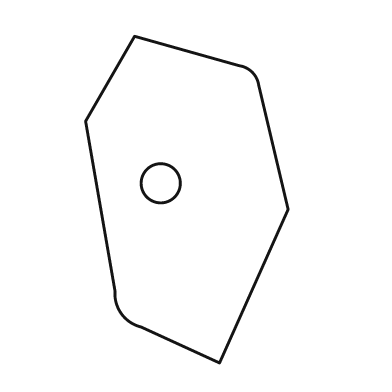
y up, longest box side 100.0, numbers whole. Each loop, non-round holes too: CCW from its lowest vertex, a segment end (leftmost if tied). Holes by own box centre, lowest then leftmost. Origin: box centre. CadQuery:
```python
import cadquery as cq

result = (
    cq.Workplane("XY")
    .moveTo(10.0, -50.0)
    .lineTo(31.0, -3.0)
    .lineTo(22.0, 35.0)
    .threePointArc((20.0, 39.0), (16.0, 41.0))
    .lineTo(-16.0, 50.0)
    .lineTo(-31.0, 24.0)
    .lineTo(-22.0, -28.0)
    .threePointArc((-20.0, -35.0), (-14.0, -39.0))
    .close()
    .moveTo(-8.0, 5.0)
    .circle(6.0)
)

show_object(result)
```